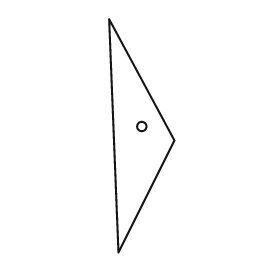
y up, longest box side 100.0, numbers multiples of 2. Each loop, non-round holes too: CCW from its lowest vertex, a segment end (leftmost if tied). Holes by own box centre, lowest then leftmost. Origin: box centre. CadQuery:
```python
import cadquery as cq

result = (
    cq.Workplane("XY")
    .moveTo(-10.0, -50.0)
    .lineTo(14.0, -2.0)
    .lineTo(-14.0, 50.0)
    .close()
    .moveTo(0.0, 4.0)
    .circle(2.0)
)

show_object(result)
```